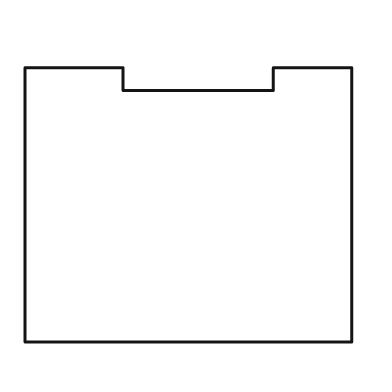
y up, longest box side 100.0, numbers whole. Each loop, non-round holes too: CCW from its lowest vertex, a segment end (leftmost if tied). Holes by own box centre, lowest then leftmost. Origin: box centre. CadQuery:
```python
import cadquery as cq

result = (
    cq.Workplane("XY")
    .moveTo(-50.0, -42.0)
    .lineTo(50.0, -42.0)
    .lineTo(50.0, 42.0)
    .lineTo(26.0, 42.0)
    .lineTo(26.0, 35.0)
    .lineTo(-20.0, 35.0)
    .lineTo(-20.0, 42.0)
    .lineTo(-50.0, 42.0)
    .close()
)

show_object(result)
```